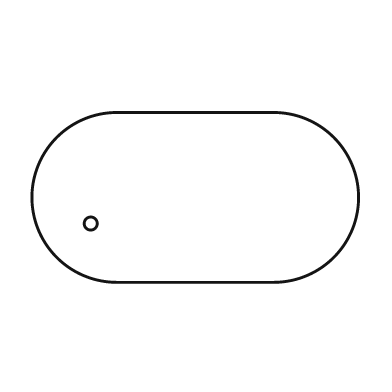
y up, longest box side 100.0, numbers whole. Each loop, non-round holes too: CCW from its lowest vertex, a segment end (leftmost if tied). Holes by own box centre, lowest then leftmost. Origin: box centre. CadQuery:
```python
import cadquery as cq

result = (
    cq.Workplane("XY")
    .moveTo(-24.0, -26.0)
    .lineTo(24.0, -26.0)
    .threePointArc((50.0, 0.0), (24.0, 26.0))
    .lineTo(-24.0, 26.0)
    .threePointArc((-50.0, 0.0), (-24.0, -26.0))
    .close()
    .moveTo(-32.0, -8.0)
    .circle(2.0)
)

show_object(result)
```